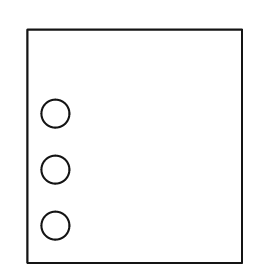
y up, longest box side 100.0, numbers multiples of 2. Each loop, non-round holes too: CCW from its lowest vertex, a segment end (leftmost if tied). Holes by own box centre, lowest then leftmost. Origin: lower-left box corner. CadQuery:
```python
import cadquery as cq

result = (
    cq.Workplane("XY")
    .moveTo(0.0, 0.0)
    .lineTo(92.0, 0.0)
    .lineTo(92.0, 100.0)
    .lineTo(0.0, 100.0)
    .close()
    .moveTo(12.0, 16.0)
    .circle(6.0)
    .moveTo(12.0, 40.0)
    .circle(6.0)
    .moveTo(12.0, 64.0)
    .circle(6.0)
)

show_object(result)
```